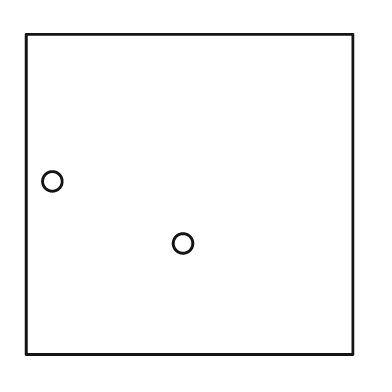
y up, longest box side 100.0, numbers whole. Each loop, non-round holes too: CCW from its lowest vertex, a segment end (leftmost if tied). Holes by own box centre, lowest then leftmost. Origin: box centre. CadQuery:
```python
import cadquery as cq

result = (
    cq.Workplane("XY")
    .moveTo(-50.0, -49.0)
    .lineTo(50.0, -49.0)
    .lineTo(50.0, 49.0)
    .lineTo(-50.0, 49.0)
    .close()
    .moveTo(-2.0, -15.0)
    .circle(3.0)
    .moveTo(-42.0, 4.0)
    .circle(3.0)
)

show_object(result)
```